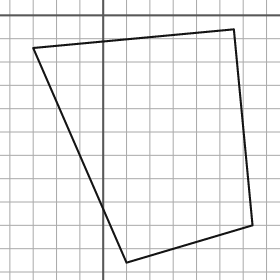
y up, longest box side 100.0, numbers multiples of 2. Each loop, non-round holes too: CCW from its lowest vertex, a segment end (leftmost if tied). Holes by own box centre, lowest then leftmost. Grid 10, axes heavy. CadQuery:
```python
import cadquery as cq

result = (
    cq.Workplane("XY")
    .moveTo(10.0, -106.0)
    .lineTo(64.0, -90.0)
    .lineTo(56.0, -6.0)
    .lineTo(-30.0, -14.0)
    .close()
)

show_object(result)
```